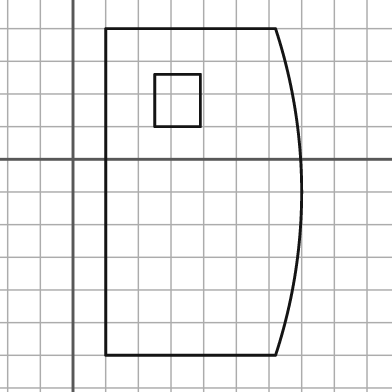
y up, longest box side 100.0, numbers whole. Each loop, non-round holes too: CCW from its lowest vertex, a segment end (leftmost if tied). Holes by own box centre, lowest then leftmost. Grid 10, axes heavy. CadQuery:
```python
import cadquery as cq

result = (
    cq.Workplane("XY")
    .moveTo(10.0, -60.0)
    .lineTo(62.0, -60.0)
    .threePointArc((70.0, -10.0), (62.0, 40.0))
    .lineTo(10.0, 40.0)
    .close()
    .moveTo(25.0, 10.0)
    .lineTo(39.0, 10.0)
    .lineTo(39.0, 26.0)
    .lineTo(25.0, 26.0)
    .close()
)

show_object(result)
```